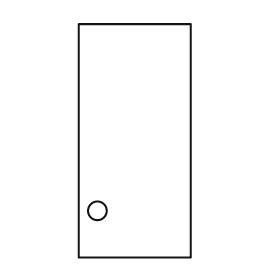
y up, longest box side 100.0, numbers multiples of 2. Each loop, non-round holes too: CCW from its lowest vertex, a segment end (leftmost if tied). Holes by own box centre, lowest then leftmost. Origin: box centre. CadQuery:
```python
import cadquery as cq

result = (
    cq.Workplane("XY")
    .moveTo(-24.0, -50.0)
    .lineTo(24.0, -50.0)
    .lineTo(24.0, 50.0)
    .lineTo(-24.0, 50.0)
    .close()
    .moveTo(-16.0, -30.0)
    .circle(4.0)
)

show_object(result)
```